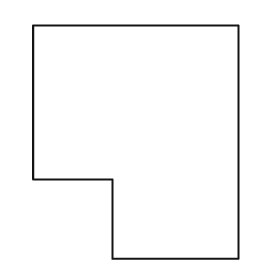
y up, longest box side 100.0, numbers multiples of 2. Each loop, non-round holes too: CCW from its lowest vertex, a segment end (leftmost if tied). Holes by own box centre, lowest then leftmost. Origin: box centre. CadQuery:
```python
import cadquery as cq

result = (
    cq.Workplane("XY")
    .moveTo(-10.0, -50.0)
    .lineTo(44.0, -50.0)
    .lineTo(44.0, 50.0)
    .lineTo(-44.0, 50.0)
    .lineTo(-44.0, -16.0)
    .lineTo(-10.0, -16.0)
    .close()
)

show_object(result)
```